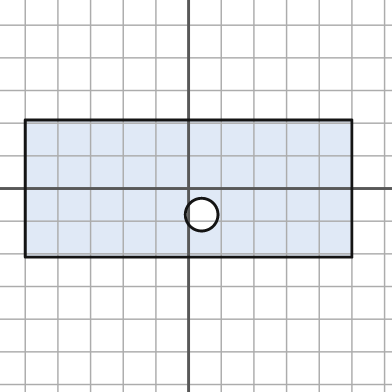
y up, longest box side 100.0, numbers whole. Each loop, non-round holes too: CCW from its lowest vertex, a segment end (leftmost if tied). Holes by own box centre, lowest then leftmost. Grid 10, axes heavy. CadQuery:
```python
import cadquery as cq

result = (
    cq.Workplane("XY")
    .moveTo(-50.0, -21.0)
    .lineTo(50.0, -21.0)
    .lineTo(50.0, 21.0)
    .lineTo(-50.0, 21.0)
    .close()
    .moveTo(4.0, -8.0)
    .circle(5.0)
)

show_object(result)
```